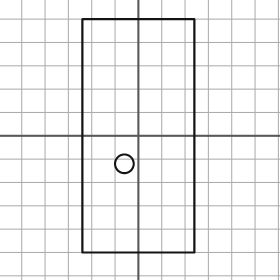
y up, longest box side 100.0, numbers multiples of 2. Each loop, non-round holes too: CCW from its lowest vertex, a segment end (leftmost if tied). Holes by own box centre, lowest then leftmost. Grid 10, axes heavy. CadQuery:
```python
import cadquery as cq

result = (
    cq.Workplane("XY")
    .moveTo(-24.0, -50.0)
    .lineTo(24.0, -50.0)
    .lineTo(24.0, 50.0)
    .lineTo(-24.0, 50.0)
    .close()
    .moveTo(-6.0, -12.0)
    .circle(4.0)
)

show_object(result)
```